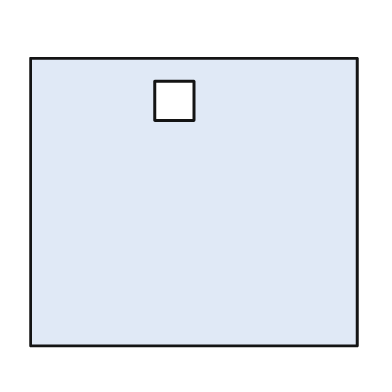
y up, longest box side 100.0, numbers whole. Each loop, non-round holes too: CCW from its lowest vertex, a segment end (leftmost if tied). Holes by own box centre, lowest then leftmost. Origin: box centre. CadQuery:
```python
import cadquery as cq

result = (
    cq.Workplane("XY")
    .moveTo(-50.0, -44.0)
    .lineTo(50.0, -44.0)
    .lineTo(50.0, 44.0)
    .lineTo(-50.0, 44.0)
    .close()
    .moveTo(-12.0, 25.0)
    .lineTo(0.0, 25.0)
    .lineTo(0.0, 37.0)
    .lineTo(-12.0, 37.0)
    .close()
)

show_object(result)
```